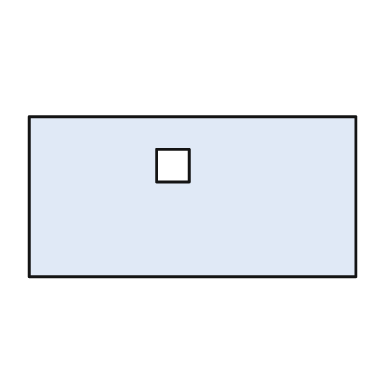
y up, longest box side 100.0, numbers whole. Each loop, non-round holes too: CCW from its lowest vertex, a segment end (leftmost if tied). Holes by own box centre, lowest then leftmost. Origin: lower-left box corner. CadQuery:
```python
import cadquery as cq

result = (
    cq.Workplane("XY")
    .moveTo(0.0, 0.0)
    .lineTo(100.0, 0.0)
    .lineTo(100.0, 49.0)
    .lineTo(0.0, 49.0)
    .close()
    .moveTo(39.0, 29.0)
    .lineTo(49.0, 29.0)
    .lineTo(49.0, 39.0)
    .lineTo(39.0, 39.0)
    .close()
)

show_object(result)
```